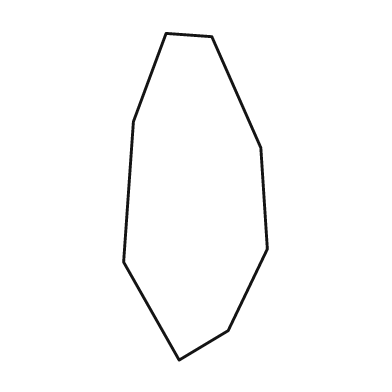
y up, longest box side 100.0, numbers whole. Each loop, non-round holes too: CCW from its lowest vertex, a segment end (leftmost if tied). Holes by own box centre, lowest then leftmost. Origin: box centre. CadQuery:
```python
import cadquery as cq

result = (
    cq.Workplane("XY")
    .moveTo(-5.0, -50.0)
    .lineTo(10.0, -41.0)
    .lineTo(22.0, -16.0)
    .lineTo(20.0, 15.0)
    .lineTo(5.0, 49.0)
    .lineTo(-9.0, 50.0)
    .lineTo(-19.0, 23.0)
    .lineTo(-22.0, -20.0)
    .close()
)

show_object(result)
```